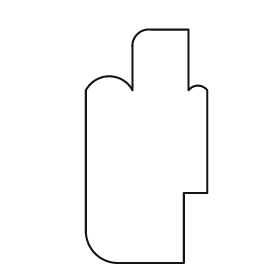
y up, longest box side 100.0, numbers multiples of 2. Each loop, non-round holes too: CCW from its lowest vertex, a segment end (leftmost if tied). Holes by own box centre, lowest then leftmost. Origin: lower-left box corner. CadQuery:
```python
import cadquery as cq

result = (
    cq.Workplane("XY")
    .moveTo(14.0, 0.0)
    .lineTo(42.0, 0.0)
    .lineTo(42.0, 30.0)
    .lineTo(52.0, 30.0)
    .lineTo(52.0, 74.0)
    .threePointArc((48.0, 76.0), (44.0, 74.0))
    .lineTo(44.0, 100.0)
    .lineTo(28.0, 100.0)
    .threePointArc((22.0, 98.0), (20.0, 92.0))
    .lineTo(20.0, 74.0)
    .threePointArc((10.0, 80.0), (0.0, 74.0))
    .lineTo(0.0, 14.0)
    .threePointArc((4.0, 4.0), (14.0, 0.0))
    .close()
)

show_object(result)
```